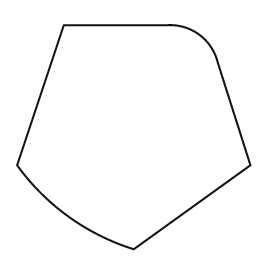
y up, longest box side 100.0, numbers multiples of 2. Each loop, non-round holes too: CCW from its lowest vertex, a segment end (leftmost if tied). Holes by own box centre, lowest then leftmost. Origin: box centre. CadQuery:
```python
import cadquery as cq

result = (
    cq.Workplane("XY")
    .moveTo(0.0, -48.0)
    .lineTo(50.0, -12.0)
    .lineTo(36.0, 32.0)
    .threePointArc((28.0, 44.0), (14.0, 48.0))
    .lineTo(-30.0, 48.0)
    .lineTo(-50.0, -12.0)
    .threePointArc((-28.0, -34.0), (0.0, -48.0))
    .close()
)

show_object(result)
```